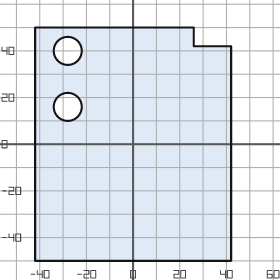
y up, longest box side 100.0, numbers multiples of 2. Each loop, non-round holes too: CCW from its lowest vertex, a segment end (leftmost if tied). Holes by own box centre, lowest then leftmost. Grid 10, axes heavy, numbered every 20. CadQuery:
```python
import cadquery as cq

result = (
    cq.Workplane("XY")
    .moveTo(-42.0, -50.0)
    .lineTo(42.0, -50.0)
    .lineTo(42.0, 42.0)
    .lineTo(26.0, 42.0)
    .lineTo(26.0, 50.0)
    .lineTo(-42.0, 50.0)
    .close()
    .moveTo(-28.0, 16.0)
    .circle(6.0)
    .moveTo(-28.0, 40.0)
    .circle(6.0)
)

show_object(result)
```